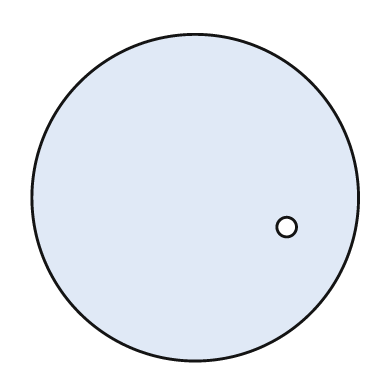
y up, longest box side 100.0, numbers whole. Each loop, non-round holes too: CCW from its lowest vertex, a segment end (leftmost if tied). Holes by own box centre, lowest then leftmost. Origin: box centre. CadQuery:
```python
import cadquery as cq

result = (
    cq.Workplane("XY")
    .moveTo(0.0, 0.0)
    .circle(50.0)
    .moveTo(28.0, -9.0)
    .circle(3.0)
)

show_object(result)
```